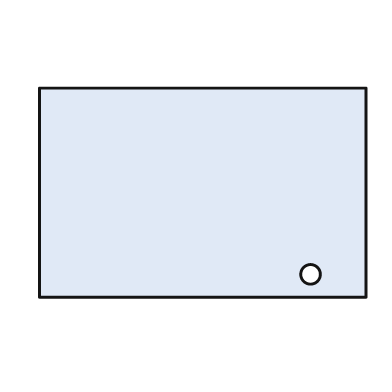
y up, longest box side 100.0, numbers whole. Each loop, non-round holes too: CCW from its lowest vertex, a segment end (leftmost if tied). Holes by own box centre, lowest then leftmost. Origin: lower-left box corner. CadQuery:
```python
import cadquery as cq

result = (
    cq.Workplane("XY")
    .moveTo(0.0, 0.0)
    .lineTo(100.0, 0.0)
    .lineTo(100.0, 64.0)
    .lineTo(0.0, 64.0)
    .close()
    .moveTo(83.0, 7.0)
    .circle(3.0)
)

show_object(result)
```